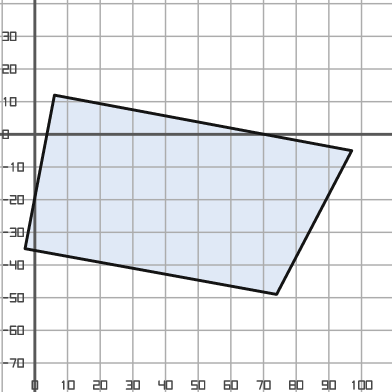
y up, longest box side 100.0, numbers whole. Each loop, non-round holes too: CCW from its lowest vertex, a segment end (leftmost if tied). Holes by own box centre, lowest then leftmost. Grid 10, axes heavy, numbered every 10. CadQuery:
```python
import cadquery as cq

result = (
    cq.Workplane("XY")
    .moveTo(74.0, -49.0)
    .lineTo(97.0, -5.0)
    .lineTo(6.0, 12.0)
    .lineTo(-3.0, -35.0)
    .close()
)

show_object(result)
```